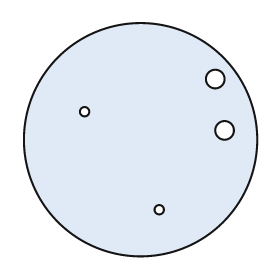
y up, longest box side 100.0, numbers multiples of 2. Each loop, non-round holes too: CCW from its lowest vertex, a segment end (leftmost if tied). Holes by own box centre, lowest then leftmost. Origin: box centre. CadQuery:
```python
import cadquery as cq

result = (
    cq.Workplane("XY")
    .moveTo(0.0, 0.0)
    .circle(50.0)
    .moveTo(8.0, -30.0)
    .circle(2.0)
    .moveTo(36.0, 4.0)
    .circle(4.0)
    .moveTo(-24.0, 12.0)
    .circle(2.0)
    .moveTo(32.0, 26.0)
    .circle(4.0)
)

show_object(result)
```